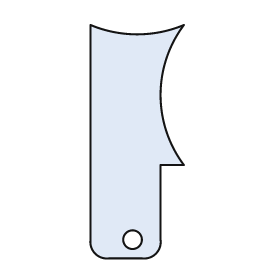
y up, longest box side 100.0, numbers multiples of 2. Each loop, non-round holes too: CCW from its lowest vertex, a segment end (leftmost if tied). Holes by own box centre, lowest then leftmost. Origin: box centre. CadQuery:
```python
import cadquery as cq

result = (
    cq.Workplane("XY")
    .moveTo(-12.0, -50.0)
    .lineTo(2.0, -50.0)
    .threePointArc((8.0, -48.0), (10.0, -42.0))
    .lineTo(10.0, -10.0)
    .lineTo(20.0, -10.0)
    .threePointArc((10.0, 20.0), (20.0, 50.0))
    .threePointArc((0.0, 46.0), (-20.0, 50.0))
    .lineTo(-20.0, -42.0)
    .threePointArc((-18.0, -48.0), (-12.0, -50.0))
    .close()
    .moveTo(-2.0, -42.0)
    .circle(4.0)
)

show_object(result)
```